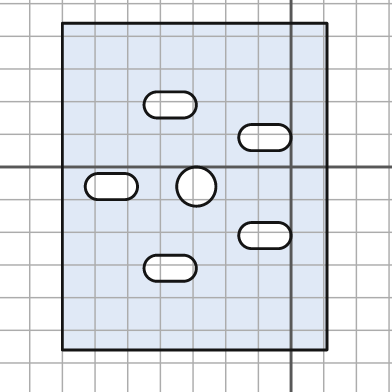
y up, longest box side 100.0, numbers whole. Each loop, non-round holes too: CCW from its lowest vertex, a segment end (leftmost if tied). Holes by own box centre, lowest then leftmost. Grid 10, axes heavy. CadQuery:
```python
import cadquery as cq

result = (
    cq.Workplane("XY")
    .moveTo(-70.0, -56.0)
    .lineTo(11.0, -56.0)
    .lineTo(11.0, 44.0)
    .lineTo(-70.0, 44.0)
    .close()
    .moveTo(-41.0, -35.0)
    .lineTo(-33.0, -35.0)
    .threePointArc((-29.0, -31.0), (-33.0, -27.0))
    .lineTo(-41.0, -27.0)
    .threePointArc((-45.0, -31.0), (-41.0, -35.0))
    .close()
    .moveTo(-12.0, -25.0)
    .lineTo(-4.0, -25.0)
    .threePointArc((0.0, -21.0), (-4.0, -17.0))
    .lineTo(-12.0, -17.0)
    .threePointArc((-16.0, -21.0), (-12.0, -25.0))
    .close()
    .moveTo(-59.0, -10.0)
    .lineTo(-51.0, -10.0)
    .threePointArc((-47.0, -6.0), (-51.0, -2.0))
    .lineTo(-59.0, -2.0)
    .threePointArc((-63.0, -6.0), (-59.0, -10.0))
    .close()
    .moveTo(-29.0, -6.0)
    .circle(6.0)
    .moveTo(-12.0, 5.0)
    .lineTo(-4.0, 5.0)
    .threePointArc((0.0, 9.0), (-4.0, 13.0))
    .lineTo(-12.0, 13.0)
    .threePointArc((-16.0, 9.0), (-12.0, 5.0))
    .close()
    .moveTo(-41.0, 15.0)
    .lineTo(-33.0, 15.0)
    .threePointArc((-29.0, 19.0), (-33.0, 23.0))
    .lineTo(-41.0, 23.0)
    .threePointArc((-45.0, 19.0), (-41.0, 15.0))
    .close()
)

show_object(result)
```